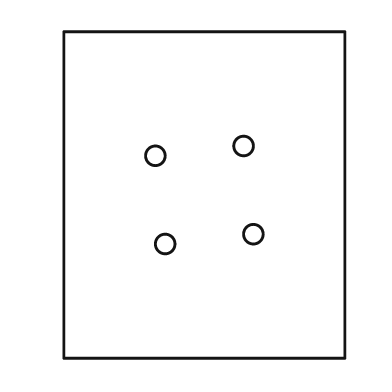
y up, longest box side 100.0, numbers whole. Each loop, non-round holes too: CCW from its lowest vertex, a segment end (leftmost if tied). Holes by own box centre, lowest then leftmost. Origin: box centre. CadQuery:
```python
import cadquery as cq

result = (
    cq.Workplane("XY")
    .moveTo(-43.0, -50.0)
    .lineTo(43.0, -50.0)
    .lineTo(43.0, 50.0)
    .lineTo(-43.0, 50.0)
    .close()
    .moveTo(-12.0, -15.0)
    .circle(3.0)
    .moveTo(15.0, -12.0)
    .circle(3.0)
    .moveTo(-15.0, 12.0)
    .circle(3.0)
    .moveTo(12.0, 15.0)
    .circle(3.0)
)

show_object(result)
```